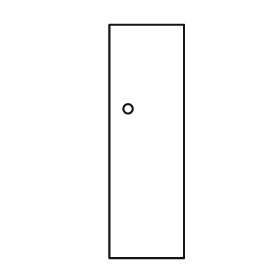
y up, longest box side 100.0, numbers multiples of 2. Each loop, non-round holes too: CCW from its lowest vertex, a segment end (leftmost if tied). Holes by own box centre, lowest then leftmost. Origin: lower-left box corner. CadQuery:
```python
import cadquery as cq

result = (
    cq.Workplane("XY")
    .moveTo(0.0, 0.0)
    .lineTo(32.0, 0.0)
    .lineTo(32.0, 100.0)
    .lineTo(0.0, 100.0)
    .close()
    .moveTo(8.0, 64.0)
    .circle(2.0)
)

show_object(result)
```